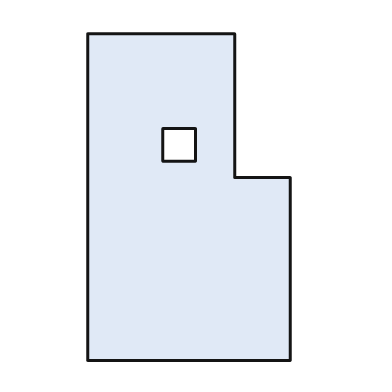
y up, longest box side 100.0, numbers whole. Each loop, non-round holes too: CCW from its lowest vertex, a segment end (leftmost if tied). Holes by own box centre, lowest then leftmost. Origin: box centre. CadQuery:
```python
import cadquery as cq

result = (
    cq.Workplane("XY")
    .moveTo(-31.0, -50.0)
    .lineTo(31.0, -50.0)
    .lineTo(31.0, 6.0)
    .lineTo(14.0, 6.0)
    .lineTo(14.0, 50.0)
    .lineTo(-31.0, 50.0)
    .close()
    .moveTo(-8.0, 11.0)
    .lineTo(2.0, 11.0)
    .lineTo(2.0, 21.0)
    .lineTo(-8.0, 21.0)
    .close()
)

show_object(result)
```